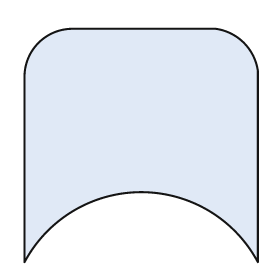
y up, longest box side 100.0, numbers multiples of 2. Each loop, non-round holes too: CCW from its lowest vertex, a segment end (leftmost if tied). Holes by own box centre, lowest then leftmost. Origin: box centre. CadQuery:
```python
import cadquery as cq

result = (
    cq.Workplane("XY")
    .moveTo(-50.0, -50.0)
    .threePointArc((0.0, -20.0), (50.0, -50.0))
    .lineTo(50.0, 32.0)
    .threePointArc((44.0, 44.0), (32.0, 50.0))
    .lineTo(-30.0, 50.0)
    .threePointArc((-44.0, 44.0), (-50.0, 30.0))
    .close()
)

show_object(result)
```